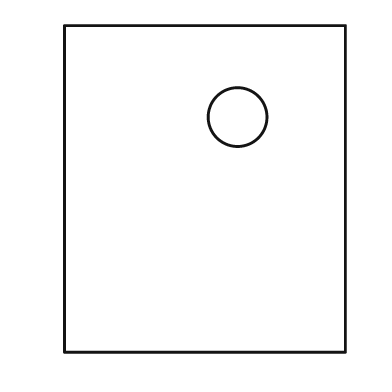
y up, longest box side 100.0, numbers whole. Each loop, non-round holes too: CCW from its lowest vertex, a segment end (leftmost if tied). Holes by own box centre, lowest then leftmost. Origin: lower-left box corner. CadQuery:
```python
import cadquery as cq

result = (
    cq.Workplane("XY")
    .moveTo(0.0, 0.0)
    .lineTo(86.0, 0.0)
    .lineTo(86.0, 100.0)
    .lineTo(0.0, 100.0)
    .close()
    .moveTo(53.0, 72.0)
    .circle(9.0)
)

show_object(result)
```